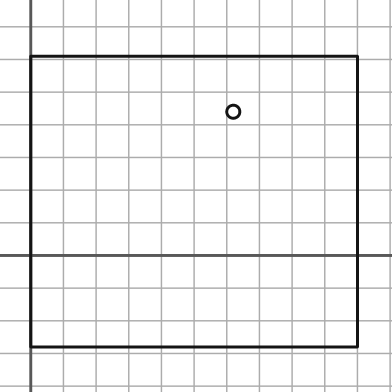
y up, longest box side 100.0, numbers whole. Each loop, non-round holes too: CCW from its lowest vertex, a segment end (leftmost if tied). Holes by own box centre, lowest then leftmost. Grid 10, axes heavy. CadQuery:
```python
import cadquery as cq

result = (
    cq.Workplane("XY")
    .moveTo(0.0, -28.0)
    .lineTo(100.0, -28.0)
    .lineTo(100.0, 61.0)
    .lineTo(0.0, 61.0)
    .close()
    .moveTo(62.0, 44.0)
    .circle(2.0)
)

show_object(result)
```